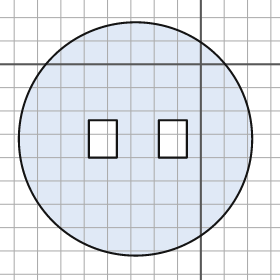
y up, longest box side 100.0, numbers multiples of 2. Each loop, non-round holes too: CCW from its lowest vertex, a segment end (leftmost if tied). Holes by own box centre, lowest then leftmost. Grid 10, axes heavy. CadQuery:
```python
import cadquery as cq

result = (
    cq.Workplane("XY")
    .moveTo(-28.0, -32.0)
    .circle(50.0)
    .moveTo(-48.0, -40.0)
    .lineTo(-36.0, -40.0)
    .lineTo(-36.0, -24.0)
    .lineTo(-48.0, -24.0)
    .close()
    .moveTo(-18.0, -40.0)
    .lineTo(-6.0, -40.0)
    .lineTo(-6.0, -24.0)
    .lineTo(-18.0, -24.0)
    .close()
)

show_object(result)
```